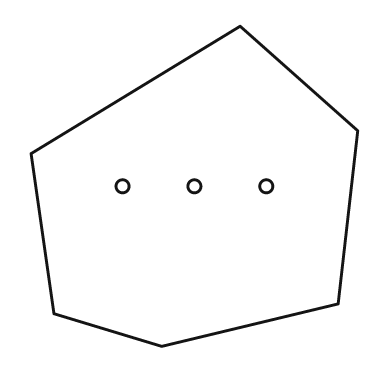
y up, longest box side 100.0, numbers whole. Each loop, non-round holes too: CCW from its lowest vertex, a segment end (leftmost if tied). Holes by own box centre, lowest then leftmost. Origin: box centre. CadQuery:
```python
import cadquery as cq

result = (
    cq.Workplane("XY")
    .moveTo(-10.0, -49.0)
    .lineTo(44.0, -36.0)
    .lineTo(50.0, 17.0)
    .lineTo(14.0, 49.0)
    .lineTo(-50.0, 10.0)
    .lineTo(-43.0, -39.0)
    .close()
    .moveTo(-22.0, 0.0)
    .circle(2.0)
    .moveTo(0.0, 0.0)
    .circle(2.0)
    .moveTo(22.0, 0.0)
    .circle(2.0)
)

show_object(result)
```